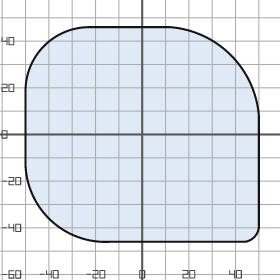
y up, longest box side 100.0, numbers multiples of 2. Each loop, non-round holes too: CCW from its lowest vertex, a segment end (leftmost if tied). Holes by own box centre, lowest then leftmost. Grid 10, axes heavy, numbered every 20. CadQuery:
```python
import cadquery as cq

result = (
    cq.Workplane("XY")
    .moveTo(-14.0, -46.0)
    .lineTo(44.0, -46.0)
    .threePointArc((48.0, -44.0), (50.0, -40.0))
    .lineTo(50.0, 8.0)
    .threePointArc((38.0, 34.0), (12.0, 46.0))
    .lineTo(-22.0, 46.0)
    .threePointArc((-42.0, 38.0), (-50.0, 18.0))
    .lineTo(-50.0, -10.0)
    .threePointArc((-40.0, -36.0), (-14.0, -46.0))
    .close()
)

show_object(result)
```